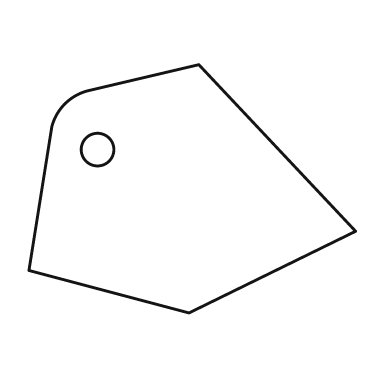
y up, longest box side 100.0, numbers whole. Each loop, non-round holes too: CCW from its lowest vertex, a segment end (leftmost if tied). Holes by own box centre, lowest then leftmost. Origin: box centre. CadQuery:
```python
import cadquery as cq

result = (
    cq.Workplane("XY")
    .moveTo(-1.0, -38.0)
    .lineTo(50.0, -13.0)
    .lineTo(2.0, 38.0)
    .lineTo(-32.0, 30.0)
    .threePointArc((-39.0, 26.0), (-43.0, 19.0))
    .lineTo(-50.0, -25.0)
    .close()
    .moveTo(-29.0, 12.0)
    .circle(5.0)
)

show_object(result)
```